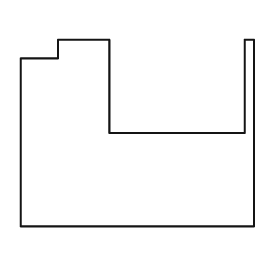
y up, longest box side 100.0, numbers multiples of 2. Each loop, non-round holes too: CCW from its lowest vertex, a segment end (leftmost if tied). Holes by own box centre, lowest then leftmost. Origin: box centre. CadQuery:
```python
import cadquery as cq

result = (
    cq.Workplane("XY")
    .moveTo(-50.0, -40.0)
    .lineTo(50.0, -40.0)
    .lineTo(50.0, 40.0)
    .lineTo(46.0, 40.0)
    .lineTo(46.0, 0.0)
    .lineTo(-12.0, 0.0)
    .lineTo(-12.0, 40.0)
    .lineTo(-34.0, 40.0)
    .lineTo(-34.0, 32.0)
    .lineTo(-50.0, 32.0)
    .close()
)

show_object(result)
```